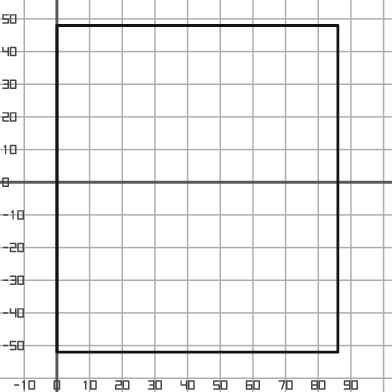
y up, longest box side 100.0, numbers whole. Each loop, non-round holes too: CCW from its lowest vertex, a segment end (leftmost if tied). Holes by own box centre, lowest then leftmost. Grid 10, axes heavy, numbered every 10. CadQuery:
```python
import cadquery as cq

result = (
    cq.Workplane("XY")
    .moveTo(0.0, -52.0)
    .lineTo(86.0, -52.0)
    .lineTo(86.0, 48.0)
    .lineTo(0.0, 48.0)
    .close()
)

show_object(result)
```